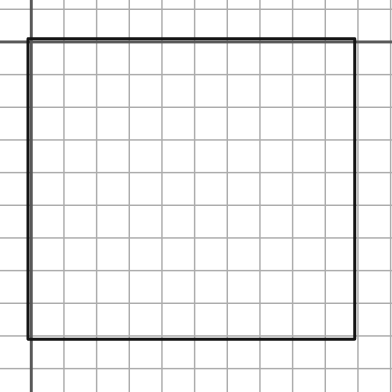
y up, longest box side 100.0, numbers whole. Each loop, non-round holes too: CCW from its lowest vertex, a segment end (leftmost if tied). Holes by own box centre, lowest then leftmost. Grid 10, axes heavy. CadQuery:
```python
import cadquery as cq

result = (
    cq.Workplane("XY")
    .moveTo(-1.0, -91.0)
    .lineTo(99.0, -91.0)
    .lineTo(99.0, 1.0)
    .lineTo(-1.0, 1.0)
    .close()
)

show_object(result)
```